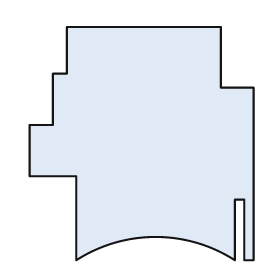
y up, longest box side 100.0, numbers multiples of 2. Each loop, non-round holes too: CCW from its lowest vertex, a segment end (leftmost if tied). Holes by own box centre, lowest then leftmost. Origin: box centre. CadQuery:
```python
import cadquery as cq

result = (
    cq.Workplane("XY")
    .moveTo(-28.0, -50.0)
    .threePointArc((6.0, -40.0), (40.0, -50.0))
    .lineTo(40.0, -24.0)
    .lineTo(44.0, -24.0)
    .lineTo(44.0, -50.0)
    .lineTo(48.0, -50.0)
    .lineTo(48.0, 24.0)
    .lineTo(34.0, 24.0)
    .lineTo(34.0, 50.0)
    .lineTo(-32.0, 50.0)
    .lineTo(-32.0, 30.0)
    .lineTo(-38.0, 30.0)
    .lineTo(-38.0, 8.0)
    .lineTo(-48.0, 8.0)
    .lineTo(-48.0, -14.0)
    .lineTo(-28.0, -14.0)
    .close()
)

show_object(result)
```